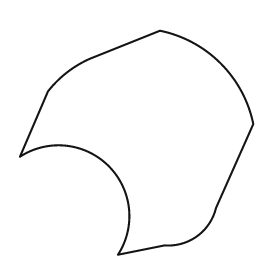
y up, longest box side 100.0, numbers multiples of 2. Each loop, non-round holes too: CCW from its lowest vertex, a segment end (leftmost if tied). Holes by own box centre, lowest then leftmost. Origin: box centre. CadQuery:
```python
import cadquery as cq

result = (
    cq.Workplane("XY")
    .moveTo(-8.0, -48.0)
    .lineTo(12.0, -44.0)
    .threePointArc((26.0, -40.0), (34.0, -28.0))
    .lineTo(50.0, 8.0)
    .threePointArc((36.0, 34.0), (10.0, 48.0))
    .lineTo(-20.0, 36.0)
    .threePointArc((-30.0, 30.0), (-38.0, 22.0))
    .lineTo(-50.0, -6.0)
    .threePointArc((-12.0, -10.0), (-8.0, -48.0))
    .close()
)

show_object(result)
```